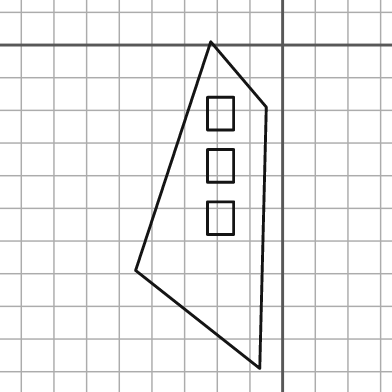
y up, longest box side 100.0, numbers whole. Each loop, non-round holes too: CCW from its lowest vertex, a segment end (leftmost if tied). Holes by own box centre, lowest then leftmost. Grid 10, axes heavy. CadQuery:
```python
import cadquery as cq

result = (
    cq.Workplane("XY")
    .moveTo(-7.0, -99.0)
    .lineTo(-5.0, -19.0)
    .lineTo(-22.0, 1.0)
    .lineTo(-45.0, -69.0)
    .close()
    .moveTo(-23.0, -58.0)
    .lineTo(-15.0, -58.0)
    .lineTo(-15.0, -48.0)
    .lineTo(-23.0, -48.0)
    .close()
    .moveTo(-23.0, -42.0)
    .lineTo(-15.0, -42.0)
    .lineTo(-15.0, -32.0)
    .lineTo(-23.0, -32.0)
    .close()
    .moveTo(-23.0, -26.0)
    .lineTo(-15.0, -26.0)
    .lineTo(-15.0, -16.0)
    .lineTo(-23.0, -16.0)
    .close()
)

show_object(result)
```